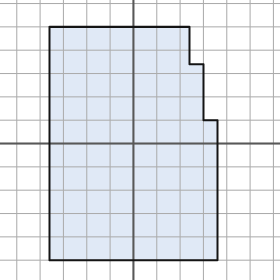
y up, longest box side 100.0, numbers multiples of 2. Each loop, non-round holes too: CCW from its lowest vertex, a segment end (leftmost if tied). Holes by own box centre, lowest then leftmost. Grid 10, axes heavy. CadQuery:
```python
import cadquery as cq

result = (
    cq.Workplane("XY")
    .moveTo(-36.0, -50.0)
    .lineTo(36.0, -50.0)
    .lineTo(36.0, 10.0)
    .lineTo(30.0, 10.0)
    .lineTo(30.0, 34.0)
    .lineTo(24.0, 34.0)
    .lineTo(24.0, 50.0)
    .lineTo(-36.0, 50.0)
    .close()
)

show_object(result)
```